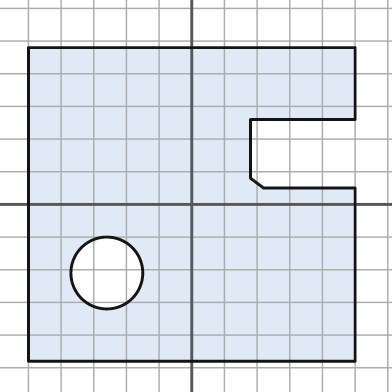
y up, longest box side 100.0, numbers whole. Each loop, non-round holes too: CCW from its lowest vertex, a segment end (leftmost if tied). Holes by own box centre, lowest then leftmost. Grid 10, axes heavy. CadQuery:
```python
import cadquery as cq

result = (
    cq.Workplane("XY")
    .moveTo(-50.0, -48.0)
    .lineTo(50.0, -48.0)
    .lineTo(50.0, 5.0)
    .lineTo(22.0, 5.0)
    .lineTo(18.0, 8.0)
    .lineTo(18.0, 26.0)
    .lineTo(50.0, 26.0)
    .lineTo(50.0, 48.0)
    .lineTo(-50.0, 48.0)
    .close()
    .moveTo(-26.0, -21.0)
    .circle(11.0)
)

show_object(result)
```